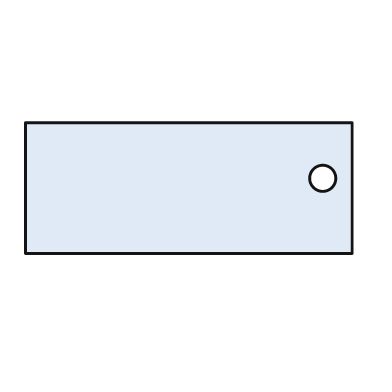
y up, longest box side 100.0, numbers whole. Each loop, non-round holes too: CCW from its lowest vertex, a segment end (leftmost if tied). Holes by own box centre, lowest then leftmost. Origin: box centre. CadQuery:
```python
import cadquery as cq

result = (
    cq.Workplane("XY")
    .moveTo(-50.0, -20.0)
    .lineTo(50.0, -20.0)
    .lineTo(50.0, 20.0)
    .lineTo(-50.0, 20.0)
    .close()
    .moveTo(41.0, 3.0)
    .circle(4.0)
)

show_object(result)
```